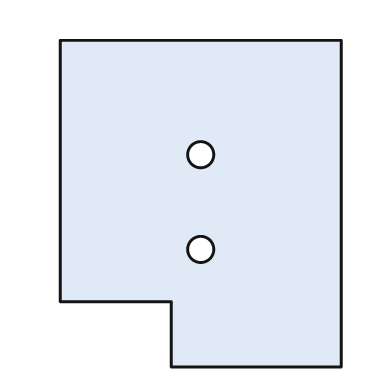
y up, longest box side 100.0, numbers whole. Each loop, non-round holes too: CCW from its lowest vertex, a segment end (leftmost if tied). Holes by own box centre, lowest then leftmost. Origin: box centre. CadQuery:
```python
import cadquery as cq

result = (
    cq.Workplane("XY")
    .moveTo(-9.0, -50.0)
    .lineTo(43.0, -50.0)
    .lineTo(43.0, 50.0)
    .lineTo(-43.0, 50.0)
    .lineTo(-43.0, -30.0)
    .lineTo(-9.0, -30.0)
    .close()
    .moveTo(0.0, -14.0)
    .circle(4.0)
    .moveTo(0.0, 15.0)
    .circle(4.0)
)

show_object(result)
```